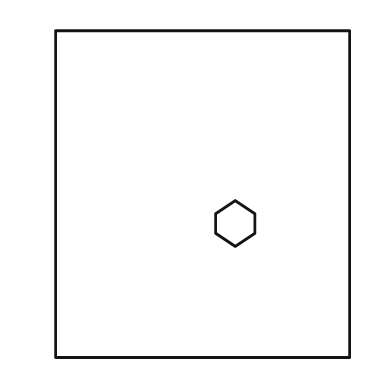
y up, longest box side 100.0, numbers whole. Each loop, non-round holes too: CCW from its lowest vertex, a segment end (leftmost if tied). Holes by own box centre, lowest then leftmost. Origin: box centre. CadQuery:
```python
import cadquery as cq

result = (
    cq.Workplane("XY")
    .moveTo(-45.0, -50.0)
    .lineTo(45.0, -50.0)
    .lineTo(45.0, 50.0)
    .lineTo(-45.0, 50.0)
    .close()
    .moveTo(10.0, -16.0)
    .lineTo(16.0, -12.0)
    .lineTo(16.0, -6.0)
    .lineTo(10.0, -2.0)
    .lineTo(4.0, -6.0)
    .lineTo(4.0, -12.0)
    .close()
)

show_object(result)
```